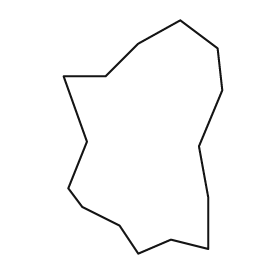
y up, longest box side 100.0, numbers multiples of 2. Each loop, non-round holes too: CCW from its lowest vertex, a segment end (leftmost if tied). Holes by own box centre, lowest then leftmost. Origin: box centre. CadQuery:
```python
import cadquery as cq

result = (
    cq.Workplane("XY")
    .moveTo(-2.0, -50.0)
    .lineTo(12.0, -44.0)
    .lineTo(28.0, -48.0)
    .lineTo(28.0, -26.0)
    .lineTo(24.0, -4.0)
    .lineTo(34.0, 20.0)
    .lineTo(32.0, 38.0)
    .lineTo(16.0, 50.0)
    .lineTo(-2.0, 40.0)
    .lineTo(-16.0, 26.0)
    .lineTo(-34.0, 26.0)
    .lineTo(-24.0, -2.0)
    .lineTo(-32.0, -22.0)
    .lineTo(-26.0, -30.0)
    .lineTo(-10.0, -38.0)
    .close()
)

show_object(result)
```